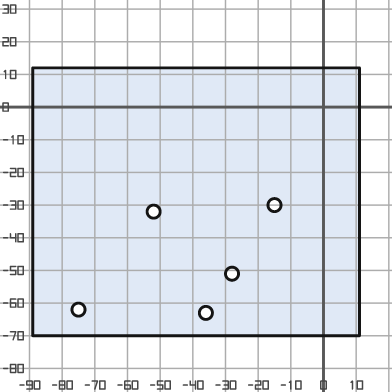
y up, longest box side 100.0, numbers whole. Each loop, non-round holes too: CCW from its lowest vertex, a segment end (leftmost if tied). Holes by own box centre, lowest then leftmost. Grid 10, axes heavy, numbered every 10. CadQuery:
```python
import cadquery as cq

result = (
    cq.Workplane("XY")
    .moveTo(-89.0, -70.0)
    .lineTo(11.0, -70.0)
    .lineTo(11.0, 12.0)
    .lineTo(-89.0, 12.0)
    .close()
    .moveTo(-36.0, -63.0)
    .circle(2.0)
    .moveTo(-75.0, -62.0)
    .circle(2.0)
    .moveTo(-28.0, -51.0)
    .circle(2.0)
    .moveTo(-52.0, -32.0)
    .circle(2.0)
    .moveTo(-15.0, -30.0)
    .circle(2.0)
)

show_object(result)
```